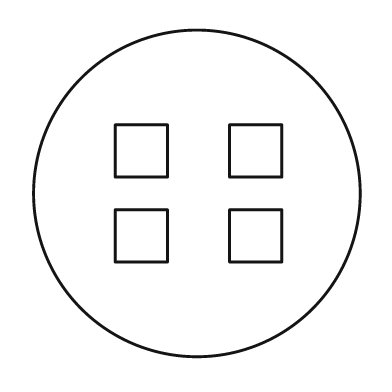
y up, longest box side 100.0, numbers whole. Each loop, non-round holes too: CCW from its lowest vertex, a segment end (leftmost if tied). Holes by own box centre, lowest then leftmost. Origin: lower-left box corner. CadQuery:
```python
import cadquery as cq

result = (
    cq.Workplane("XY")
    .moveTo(50.0, 50.0)
    .circle(50.0)
    .moveTo(25.0, 29.0)
    .lineTo(41.0, 29.0)
    .lineTo(41.0, 45.0)
    .lineTo(25.0, 45.0)
    .close()
    .moveTo(60.0, 29.0)
    .lineTo(76.0, 29.0)
    .lineTo(76.0, 45.0)
    .lineTo(60.0, 45.0)
    .close()
    .moveTo(25.0, 55.0)
    .lineTo(41.0, 55.0)
    .lineTo(41.0, 71.0)
    .lineTo(25.0, 71.0)
    .close()
    .moveTo(60.0, 55.0)
    .lineTo(76.0, 55.0)
    .lineTo(76.0, 71.0)
    .lineTo(60.0, 71.0)
    .close()
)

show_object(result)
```